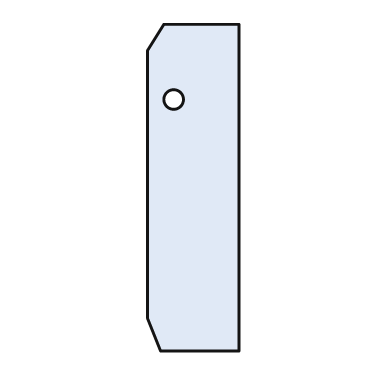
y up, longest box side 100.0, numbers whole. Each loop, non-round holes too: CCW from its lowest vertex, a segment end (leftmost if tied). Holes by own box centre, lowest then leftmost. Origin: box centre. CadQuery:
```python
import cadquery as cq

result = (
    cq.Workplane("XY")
    .moveTo(-10.0, -50.0)
    .lineTo(14.0, -50.0)
    .lineTo(14.0, 50.0)
    .lineTo(-9.0, 50.0)
    .lineTo(-14.0, 42.0)
    .lineTo(-14.0, -40.0)
    .close()
    .moveTo(-6.0, 27.0)
    .circle(3.0)
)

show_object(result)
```